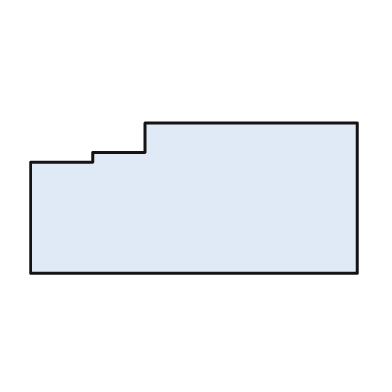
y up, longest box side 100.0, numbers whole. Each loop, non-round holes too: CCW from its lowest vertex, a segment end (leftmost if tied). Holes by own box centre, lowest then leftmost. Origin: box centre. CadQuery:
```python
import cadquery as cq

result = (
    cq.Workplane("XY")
    .moveTo(-50.0, -23.0)
    .lineTo(50.0, -23.0)
    .lineTo(50.0, 23.0)
    .lineTo(-15.0, 23.0)
    .lineTo(-15.0, 14.0)
    .lineTo(-31.0, 14.0)
    .lineTo(-31.0, 11.0)
    .lineTo(-50.0, 11.0)
    .close()
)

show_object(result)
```